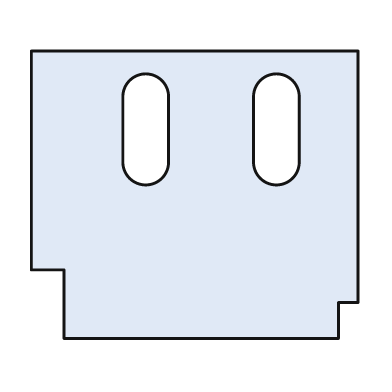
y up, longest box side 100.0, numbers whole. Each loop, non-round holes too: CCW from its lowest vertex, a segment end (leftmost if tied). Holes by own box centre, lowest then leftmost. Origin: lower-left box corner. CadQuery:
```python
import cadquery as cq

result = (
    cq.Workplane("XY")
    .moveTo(10.0, 0.0)
    .lineTo(94.0, 0.0)
    .lineTo(94.0, 11.0)
    .lineTo(100.0, 11.0)
    .lineTo(100.0, 88.0)
    .lineTo(0.0, 88.0)
    .lineTo(0.0, 21.0)
    .lineTo(10.0, 21.0)
    .close()
    .moveTo(28.0, 54.0)
    .threePointArc((35.0, 47.0), (42.0, 54.0))
    .lineTo(42.0, 74.0)
    .threePointArc((35.0, 81.0), (28.0, 74.0))
    .close()
    .moveTo(68.0, 54.0)
    .threePointArc((75.0, 47.0), (82.0, 54.0))
    .lineTo(82.0, 74.0)
    .threePointArc((75.0, 81.0), (68.0, 74.0))
    .close()
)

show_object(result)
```